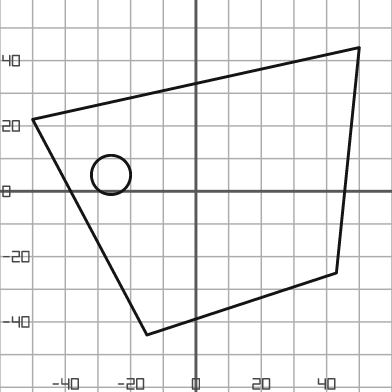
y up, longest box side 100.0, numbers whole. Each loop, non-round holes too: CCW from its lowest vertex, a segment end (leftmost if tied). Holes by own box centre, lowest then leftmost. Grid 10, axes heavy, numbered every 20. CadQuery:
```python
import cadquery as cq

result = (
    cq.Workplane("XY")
    .moveTo(-15.0, -44.0)
    .lineTo(43.0, -25.0)
    .lineTo(50.0, 44.0)
    .lineTo(-50.0, 22.0)
    .close()
    .moveTo(-26.0, 5.0)
    .circle(6.0)
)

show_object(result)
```